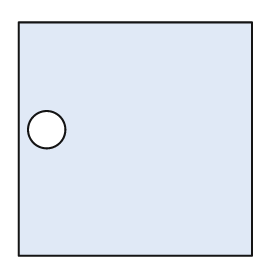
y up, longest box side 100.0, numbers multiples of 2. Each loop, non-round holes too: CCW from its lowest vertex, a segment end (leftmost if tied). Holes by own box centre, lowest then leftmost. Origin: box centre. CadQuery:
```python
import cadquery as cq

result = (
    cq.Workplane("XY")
    .moveTo(-50.0, -50.0)
    .lineTo(50.0, -50.0)
    .lineTo(50.0, 50.0)
    .lineTo(-50.0, 50.0)
    .close()
    .moveTo(-38.0, 4.0)
    .circle(8.0)
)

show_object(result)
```